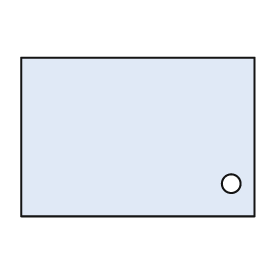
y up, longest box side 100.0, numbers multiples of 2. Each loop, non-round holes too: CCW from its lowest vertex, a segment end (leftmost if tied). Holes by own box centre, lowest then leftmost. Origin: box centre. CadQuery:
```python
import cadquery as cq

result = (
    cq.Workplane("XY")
    .moveTo(-50.0, -34.0)
    .lineTo(50.0, -34.0)
    .lineTo(50.0, 34.0)
    .lineTo(-50.0, 34.0)
    .close()
    .moveTo(40.0, -20.0)
    .circle(4.0)
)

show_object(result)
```